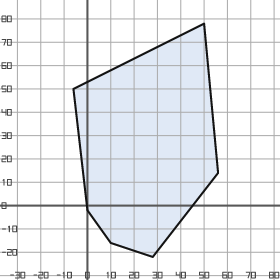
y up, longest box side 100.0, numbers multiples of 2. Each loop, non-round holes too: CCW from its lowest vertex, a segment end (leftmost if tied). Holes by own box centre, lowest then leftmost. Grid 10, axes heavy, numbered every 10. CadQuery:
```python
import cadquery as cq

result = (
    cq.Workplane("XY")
    .moveTo(28.0, -22.0)
    .lineTo(56.0, 14.0)
    .lineTo(50.0, 78.0)
    .lineTo(-6.0, 50.0)
    .lineTo(0.0, -2.0)
    .lineTo(10.0, -16.0)
    .close()
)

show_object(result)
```